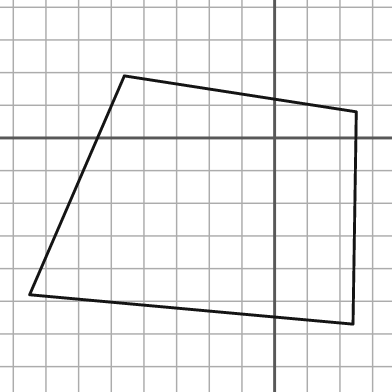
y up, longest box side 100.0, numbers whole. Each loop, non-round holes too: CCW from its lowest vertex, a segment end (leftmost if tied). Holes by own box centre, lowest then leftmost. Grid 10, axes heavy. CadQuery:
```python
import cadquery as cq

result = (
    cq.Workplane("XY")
    .moveTo(24.0, -57.0)
    .lineTo(25.0, 8.0)
    .lineTo(-46.0, 19.0)
    .lineTo(-75.0, -48.0)
    .close()
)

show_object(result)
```